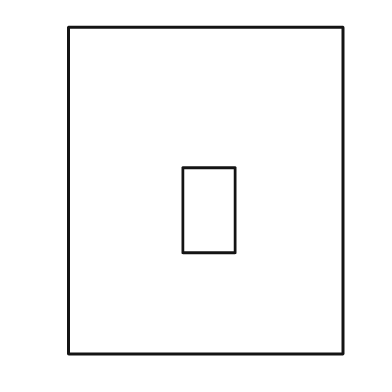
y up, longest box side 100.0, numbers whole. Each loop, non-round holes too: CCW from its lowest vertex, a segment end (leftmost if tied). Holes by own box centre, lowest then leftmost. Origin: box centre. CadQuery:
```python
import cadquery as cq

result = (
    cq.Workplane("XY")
    .moveTo(-42.0, -50.0)
    .lineTo(42.0, -50.0)
    .lineTo(42.0, 50.0)
    .lineTo(-42.0, 50.0)
    .close()
    .moveTo(-7.0, -19.0)
    .lineTo(9.0, -19.0)
    .lineTo(9.0, 7.0)
    .lineTo(-7.0, 7.0)
    .close()
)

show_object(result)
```